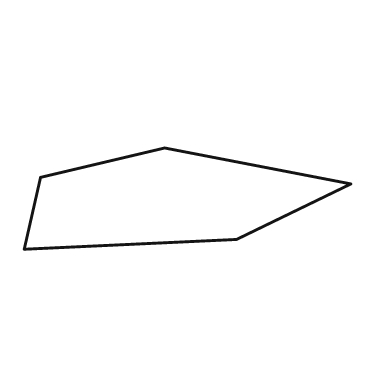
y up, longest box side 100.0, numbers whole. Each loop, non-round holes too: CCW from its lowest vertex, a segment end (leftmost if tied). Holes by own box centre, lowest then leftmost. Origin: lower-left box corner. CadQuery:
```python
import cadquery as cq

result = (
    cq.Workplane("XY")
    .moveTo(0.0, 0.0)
    .lineTo(65.0, 3.0)
    .lineTo(100.0, 20.0)
    .lineTo(43.0, 31.0)
    .lineTo(5.0, 22.0)
    .close()
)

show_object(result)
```